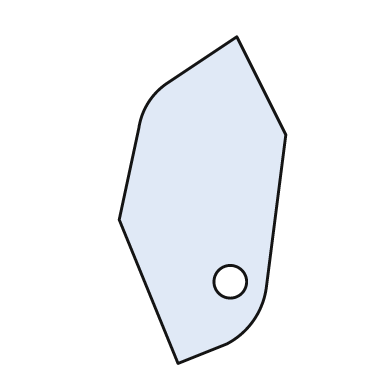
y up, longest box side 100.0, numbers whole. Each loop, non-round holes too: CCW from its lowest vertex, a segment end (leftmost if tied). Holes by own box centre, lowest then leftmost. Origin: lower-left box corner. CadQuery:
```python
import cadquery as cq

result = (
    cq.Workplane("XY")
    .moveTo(18.0, 0.0)
    .lineTo(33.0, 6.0)
    .threePointArc((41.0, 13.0), (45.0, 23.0))
    .lineTo(51.0, 70.0)
    .lineTo(36.0, 100.0)
    .lineTo(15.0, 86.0)
    .threePointArc((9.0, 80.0), (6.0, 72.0))
    .lineTo(0.0, 44.0)
    .close()
    .moveTo(34.0, 25.0)
    .circle(5.0)
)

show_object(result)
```